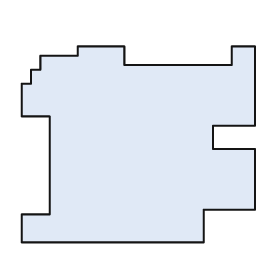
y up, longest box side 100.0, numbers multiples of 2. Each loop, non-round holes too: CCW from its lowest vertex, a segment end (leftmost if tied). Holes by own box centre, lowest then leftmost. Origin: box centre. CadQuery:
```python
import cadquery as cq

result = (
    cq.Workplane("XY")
    .moveTo(-50.0, -42.0)
    .lineTo(28.0, -42.0)
    .lineTo(28.0, -28.0)
    .lineTo(50.0, -28.0)
    .lineTo(50.0, -2.0)
    .lineTo(32.0, -2.0)
    .lineTo(32.0, 8.0)
    .lineTo(50.0, 8.0)
    .lineTo(50.0, 42.0)
    .lineTo(40.0, 42.0)
    .lineTo(40.0, 34.0)
    .lineTo(-6.0, 34.0)
    .lineTo(-6.0, 42.0)
    .lineTo(-26.0, 42.0)
    .lineTo(-26.0, 38.0)
    .lineTo(-42.0, 38.0)
    .lineTo(-42.0, 32.0)
    .lineTo(-46.0, 32.0)
    .lineTo(-46.0, 26.0)
    .lineTo(-50.0, 26.0)
    .lineTo(-50.0, 12.0)
    .lineTo(-38.0, 12.0)
    .lineTo(-38.0, -30.0)
    .lineTo(-50.0, -30.0)
    .close()
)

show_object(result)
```